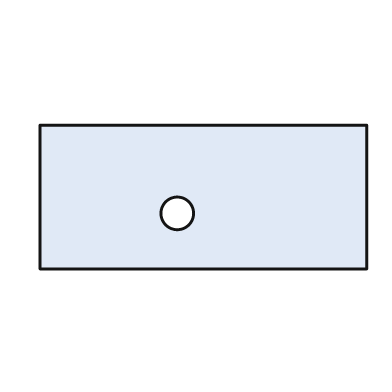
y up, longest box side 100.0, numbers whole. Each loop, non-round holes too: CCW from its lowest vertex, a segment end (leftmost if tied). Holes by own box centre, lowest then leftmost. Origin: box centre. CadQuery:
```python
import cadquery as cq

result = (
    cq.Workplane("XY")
    .moveTo(-50.0, -22.0)
    .lineTo(50.0, -22.0)
    .lineTo(50.0, 22.0)
    .lineTo(-50.0, 22.0)
    .close()
    .moveTo(-8.0, -5.0)
    .circle(5.0)
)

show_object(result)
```